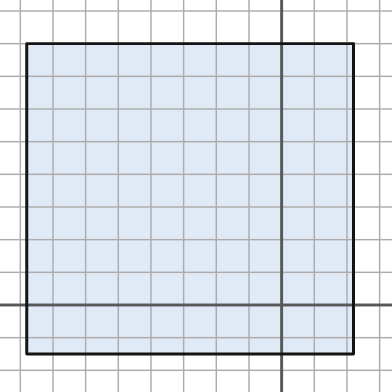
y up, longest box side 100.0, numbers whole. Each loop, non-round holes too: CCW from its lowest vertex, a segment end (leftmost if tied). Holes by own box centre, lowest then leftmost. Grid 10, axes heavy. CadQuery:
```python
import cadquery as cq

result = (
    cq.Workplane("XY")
    .moveTo(-78.0, -15.0)
    .lineTo(22.0, -15.0)
    .lineTo(22.0, 80.0)
    .lineTo(-78.0, 80.0)
    .close()
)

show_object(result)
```